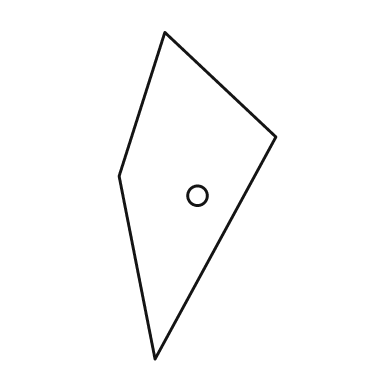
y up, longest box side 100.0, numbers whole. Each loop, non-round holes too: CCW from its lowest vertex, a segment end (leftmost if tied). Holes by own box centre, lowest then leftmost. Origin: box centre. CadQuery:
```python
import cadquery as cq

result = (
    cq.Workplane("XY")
    .moveTo(-13.0, -50.0)
    .lineTo(24.0, 18.0)
    .lineTo(-10.0, 50.0)
    .lineTo(-24.0, 6.0)
    .close()
    .moveTo(0.0, 0.0)
    .circle(3.0)
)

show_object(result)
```